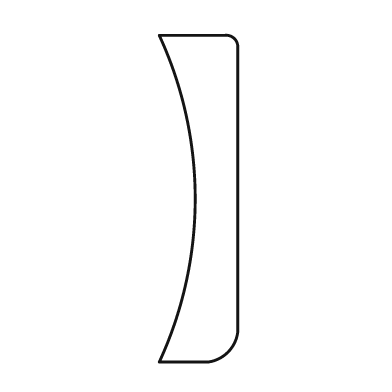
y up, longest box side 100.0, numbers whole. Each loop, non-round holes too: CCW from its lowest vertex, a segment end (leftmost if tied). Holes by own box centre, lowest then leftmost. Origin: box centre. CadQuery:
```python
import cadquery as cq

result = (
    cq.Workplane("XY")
    .moveTo(-12.0, -50.0)
    .lineTo(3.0, -50.0)
    .threePointArc((9.0, -47.0), (12.0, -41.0))
    .lineTo(12.0, 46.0)
    .threePointArc((11.0, 49.0), (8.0, 50.0))
    .lineTo(-12.0, 50.0)
    .threePointArc((-1.0, 0.0), (-12.0, -50.0))
    .close()
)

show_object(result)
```